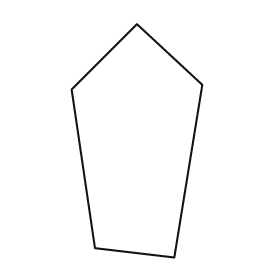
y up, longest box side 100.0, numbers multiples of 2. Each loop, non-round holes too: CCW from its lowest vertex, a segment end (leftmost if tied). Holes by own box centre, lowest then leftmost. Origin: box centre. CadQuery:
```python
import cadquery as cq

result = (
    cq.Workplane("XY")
    .moveTo(16.0, -50.0)
    .lineTo(28.0, 24.0)
    .lineTo(0.0, 50.0)
    .lineTo(-28.0, 22.0)
    .lineTo(-18.0, -46.0)
    .close()
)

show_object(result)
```